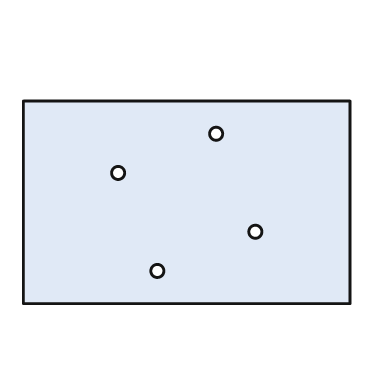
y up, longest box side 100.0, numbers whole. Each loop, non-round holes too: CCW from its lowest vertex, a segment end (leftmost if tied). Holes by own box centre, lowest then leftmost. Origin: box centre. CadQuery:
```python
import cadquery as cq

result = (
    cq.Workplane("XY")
    .moveTo(-50.0, -31.0)
    .lineTo(50.0, -31.0)
    .lineTo(50.0, 31.0)
    .lineTo(-50.0, 31.0)
    .close()
    .moveTo(-9.0, -21.0)
    .circle(2.0)
    .moveTo(21.0, -9.0)
    .circle(2.0)
    .moveTo(-21.0, 9.0)
    .circle(2.0)
    .moveTo(9.0, 21.0)
    .circle(2.0)
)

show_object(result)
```